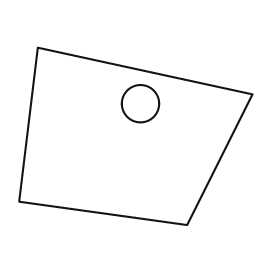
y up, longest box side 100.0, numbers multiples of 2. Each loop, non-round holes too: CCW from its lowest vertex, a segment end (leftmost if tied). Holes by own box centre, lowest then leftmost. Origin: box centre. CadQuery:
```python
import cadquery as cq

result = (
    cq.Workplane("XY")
    .moveTo(22.0, -38.0)
    .lineTo(50.0, 18.0)
    .lineTo(-42.0, 38.0)
    .lineTo(-50.0, -28.0)
    .close()
    .moveTo(2.0, 14.0)
    .circle(8.0)
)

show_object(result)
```